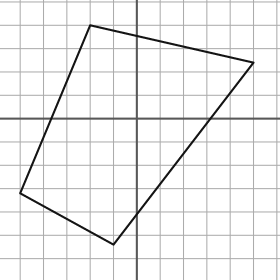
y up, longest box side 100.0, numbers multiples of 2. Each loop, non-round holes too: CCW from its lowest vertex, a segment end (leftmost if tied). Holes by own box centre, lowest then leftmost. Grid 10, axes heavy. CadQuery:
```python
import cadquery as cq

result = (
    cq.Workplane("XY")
    .moveTo(-10.0, -54.0)
    .lineTo(50.0, 24.0)
    .lineTo(-20.0, 40.0)
    .lineTo(-50.0, -32.0)
    .close()
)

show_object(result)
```